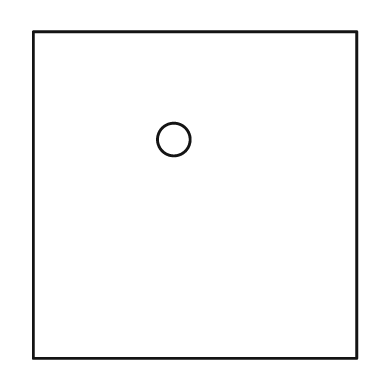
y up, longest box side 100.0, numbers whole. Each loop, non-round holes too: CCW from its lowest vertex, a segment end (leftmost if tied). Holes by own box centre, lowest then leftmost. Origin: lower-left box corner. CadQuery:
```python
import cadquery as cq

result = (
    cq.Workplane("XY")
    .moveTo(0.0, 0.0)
    .lineTo(99.0, 0.0)
    .lineTo(99.0, 100.0)
    .lineTo(0.0, 100.0)
    .close()
    .moveTo(43.0, 67.0)
    .circle(5.0)
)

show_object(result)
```